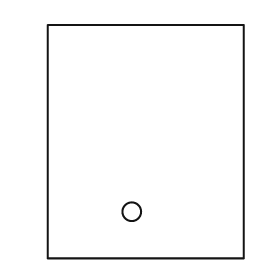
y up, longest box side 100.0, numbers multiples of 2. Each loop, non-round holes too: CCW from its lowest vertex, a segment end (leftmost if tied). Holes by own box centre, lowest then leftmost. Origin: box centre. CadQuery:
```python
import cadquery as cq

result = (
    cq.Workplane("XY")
    .moveTo(-42.0, -50.0)
    .lineTo(42.0, -50.0)
    .lineTo(42.0, 50.0)
    .lineTo(-42.0, 50.0)
    .close()
    .moveTo(-6.0, -30.0)
    .circle(4.0)
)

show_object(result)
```